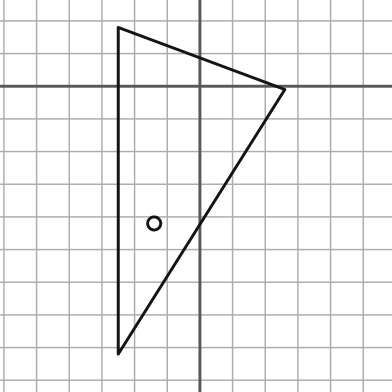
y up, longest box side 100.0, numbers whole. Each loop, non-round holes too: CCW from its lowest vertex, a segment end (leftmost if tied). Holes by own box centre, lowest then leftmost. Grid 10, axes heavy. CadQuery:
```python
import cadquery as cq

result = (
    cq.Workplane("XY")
    .moveTo(-25.0, -82.0)
    .lineTo(26.0, -1.0)
    .lineTo(-25.0, 18.0)
    .close()
    .moveTo(-14.0, -42.0)
    .circle(2.0)
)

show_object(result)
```